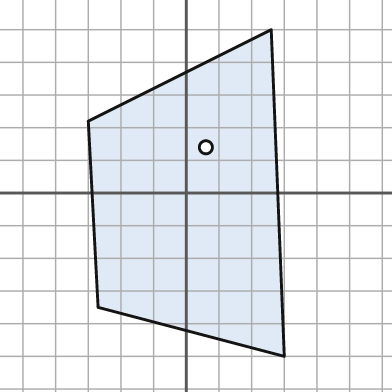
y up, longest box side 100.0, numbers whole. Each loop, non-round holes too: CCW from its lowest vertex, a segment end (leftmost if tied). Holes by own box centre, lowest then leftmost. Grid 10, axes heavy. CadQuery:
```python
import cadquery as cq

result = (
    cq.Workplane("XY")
    .moveTo(30.0, -50.0)
    .lineTo(26.0, 50.0)
    .lineTo(-30.0, 22.0)
    .lineTo(-27.0, -35.0)
    .close()
    .moveTo(6.0, 14.0)
    .circle(2.0)
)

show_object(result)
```